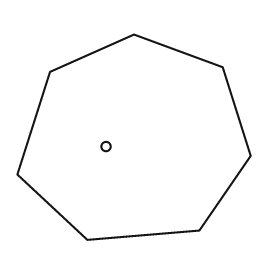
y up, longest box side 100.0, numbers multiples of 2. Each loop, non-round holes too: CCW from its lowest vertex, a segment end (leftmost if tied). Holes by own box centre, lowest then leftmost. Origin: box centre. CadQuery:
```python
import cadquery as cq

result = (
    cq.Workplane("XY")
    .moveTo(-20.0, -44.0)
    .lineTo(28.0, -40.0)
    .lineTo(50.0, -8.0)
    .lineTo(38.0, 30.0)
    .lineTo(0.0, 44.0)
    .lineTo(-36.0, 28.0)
    .lineTo(-50.0, -16.0)
    .close()
    .moveTo(-12.0, -4.0)
    .circle(2.0)
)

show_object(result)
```